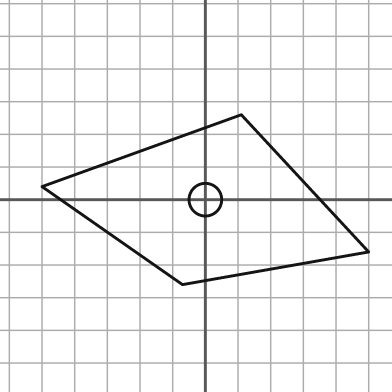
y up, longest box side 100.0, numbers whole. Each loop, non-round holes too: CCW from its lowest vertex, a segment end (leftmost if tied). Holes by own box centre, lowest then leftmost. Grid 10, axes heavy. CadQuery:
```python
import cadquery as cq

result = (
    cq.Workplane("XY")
    .moveTo(-7.0, -26.0)
    .lineTo(50.0, -16.0)
    .lineTo(11.0, 26.0)
    .lineTo(-50.0, 4.0)
    .close()
    .moveTo(0.0, 0.0)
    .circle(5.0)
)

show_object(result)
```